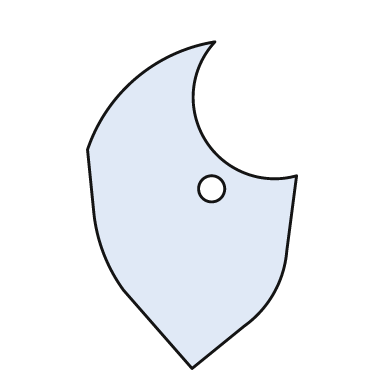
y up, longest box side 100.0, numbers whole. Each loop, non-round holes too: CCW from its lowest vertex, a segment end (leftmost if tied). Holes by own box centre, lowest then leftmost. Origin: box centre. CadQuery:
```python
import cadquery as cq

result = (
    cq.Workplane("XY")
    .moveTo(0.0, -50.0)
    .lineTo(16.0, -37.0)
    .threePointArc((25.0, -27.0), (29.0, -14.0))
    .lineTo(32.0, 9.0)
    .threePointArc((4.0, 20.0), (7.0, 50.0))
    .threePointArc((-17.0, 39.0), (-32.0, 17.0))
    .lineTo(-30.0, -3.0)
    .threePointArc((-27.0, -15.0), (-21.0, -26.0))
    .close()
    .moveTo(6.0, 5.0)
    .circle(4.0)
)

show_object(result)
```